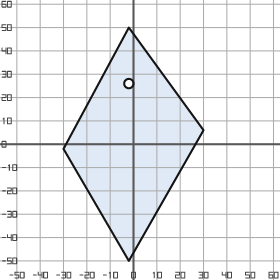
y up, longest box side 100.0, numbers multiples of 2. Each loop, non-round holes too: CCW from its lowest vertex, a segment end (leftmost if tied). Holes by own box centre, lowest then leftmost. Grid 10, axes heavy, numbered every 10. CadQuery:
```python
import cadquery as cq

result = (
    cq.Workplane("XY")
    .moveTo(-2.0, -50.0)
    .lineTo(30.0, 6.0)
    .lineTo(-2.0, 50.0)
    .lineTo(-30.0, -2.0)
    .close()
    .moveTo(-2.0, 26.0)
    .circle(2.0)
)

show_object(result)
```